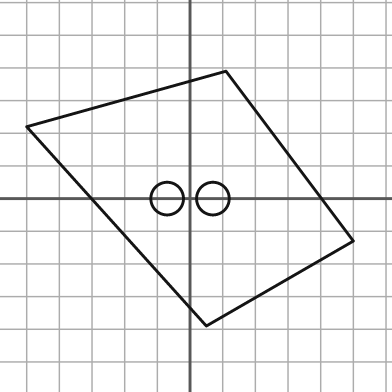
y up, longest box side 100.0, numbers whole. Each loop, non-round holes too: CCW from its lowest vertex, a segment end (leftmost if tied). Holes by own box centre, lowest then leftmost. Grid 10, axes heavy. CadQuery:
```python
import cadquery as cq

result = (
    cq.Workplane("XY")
    .moveTo(5.0, -39.0)
    .lineTo(50.0, -13.0)
    .lineTo(11.0, 39.0)
    .lineTo(-50.0, 22.0)
    .close()
    .moveTo(-7.0, 0.0)
    .circle(5.0)
    .moveTo(7.0, 0.0)
    .circle(5.0)
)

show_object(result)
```